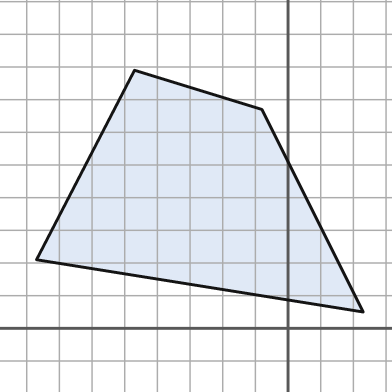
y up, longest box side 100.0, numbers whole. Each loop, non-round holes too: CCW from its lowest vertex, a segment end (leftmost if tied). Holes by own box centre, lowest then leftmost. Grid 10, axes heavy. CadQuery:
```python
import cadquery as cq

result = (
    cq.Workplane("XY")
    .moveTo(23.0, 5.0)
    .lineTo(-8.0, 67.0)
    .lineTo(-47.0, 79.0)
    .lineTo(-77.0, 21.0)
    .close()
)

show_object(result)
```